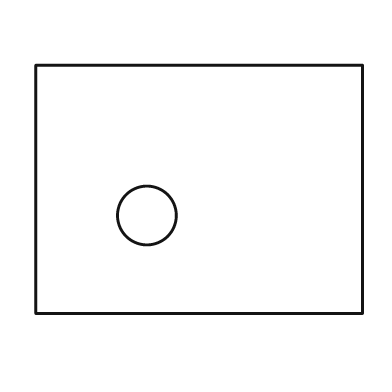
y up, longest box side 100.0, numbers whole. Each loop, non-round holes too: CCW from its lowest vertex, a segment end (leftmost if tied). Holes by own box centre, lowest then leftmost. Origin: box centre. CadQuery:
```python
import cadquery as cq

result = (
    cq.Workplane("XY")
    .moveTo(-50.0, -38.0)
    .lineTo(50.0, -38.0)
    .lineTo(50.0, 38.0)
    .lineTo(-50.0, 38.0)
    .close()
    .moveTo(-16.0, -8.0)
    .circle(9.0)
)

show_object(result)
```